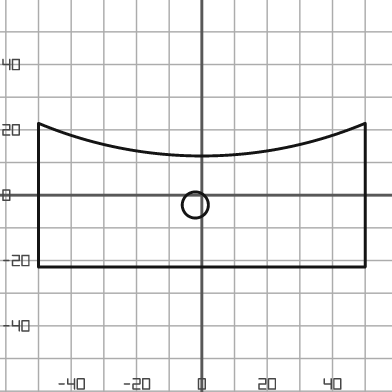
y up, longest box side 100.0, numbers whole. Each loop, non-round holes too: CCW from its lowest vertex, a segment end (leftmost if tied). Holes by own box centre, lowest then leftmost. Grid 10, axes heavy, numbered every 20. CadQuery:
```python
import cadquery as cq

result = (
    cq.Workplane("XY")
    .moveTo(-50.0, -22.0)
    .lineTo(50.0, -22.0)
    .lineTo(50.0, 22.0)
    .threePointArc((0.0, 12.0), (-50.0, 22.0))
    .close()
    .moveTo(-2.0, -3.0)
    .circle(4.0)
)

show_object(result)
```